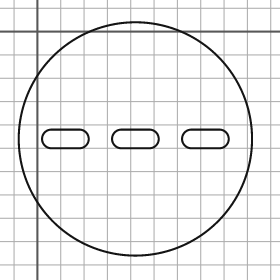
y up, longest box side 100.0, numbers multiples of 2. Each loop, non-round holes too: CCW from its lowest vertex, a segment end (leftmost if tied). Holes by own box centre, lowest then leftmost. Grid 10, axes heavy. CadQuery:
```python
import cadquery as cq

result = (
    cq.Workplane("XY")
    .moveTo(42.0, -46.0)
    .circle(50.0)
    .moveTo(6.0, -50.0)
    .lineTo(18.0, -50.0)
    .threePointArc((22.0, -46.0), (18.0, -42.0))
    .lineTo(6.0, -42.0)
    .threePointArc((2.0, -46.0), (6.0, -50.0))
    .close()
    .moveTo(36.0, -50.0)
    .lineTo(48.0, -50.0)
    .threePointArc((52.0, -46.0), (48.0, -42.0))
    .lineTo(36.0, -42.0)
    .threePointArc((32.0, -46.0), (36.0, -50.0))
    .close()
    .moveTo(66.0, -50.0)
    .lineTo(78.0, -50.0)
    .threePointArc((82.0, -46.0), (78.0, -42.0))
    .lineTo(66.0, -42.0)
    .threePointArc((62.0, -46.0), (66.0, -50.0))
    .close()
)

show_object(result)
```